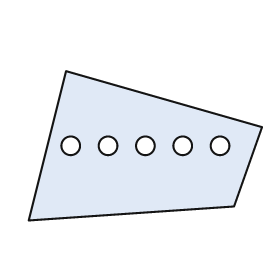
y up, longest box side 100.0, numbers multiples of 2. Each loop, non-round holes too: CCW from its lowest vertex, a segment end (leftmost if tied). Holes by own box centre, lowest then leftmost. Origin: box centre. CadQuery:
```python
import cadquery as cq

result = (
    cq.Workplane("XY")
    .moveTo(-50.0, -32.0)
    .lineTo(38.0, -26.0)
    .lineTo(50.0, 8.0)
    .lineTo(-34.0, 32.0)
    .close()
    .moveTo(-32.0, 0.0)
    .circle(4.0)
    .moveTo(-16.0, 0.0)
    .circle(4.0)
    .moveTo(0.0, 0.0)
    .circle(4.0)
    .moveTo(16.0, 0.0)
    .circle(4.0)
    .moveTo(32.0, 0.0)
    .circle(4.0)
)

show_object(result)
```